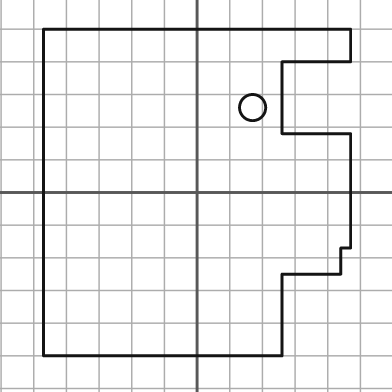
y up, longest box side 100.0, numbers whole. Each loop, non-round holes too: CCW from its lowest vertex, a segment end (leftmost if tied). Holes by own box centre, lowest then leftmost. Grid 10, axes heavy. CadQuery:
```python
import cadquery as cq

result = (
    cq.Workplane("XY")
    .moveTo(-47.0, -50.0)
    .lineTo(26.0, -50.0)
    .lineTo(26.0, -25.0)
    .lineTo(44.0, -25.0)
    .lineTo(44.0, -17.0)
    .lineTo(47.0, -17.0)
    .lineTo(47.0, 18.0)
    .lineTo(26.0, 18.0)
    .lineTo(26.0, 40.0)
    .lineTo(47.0, 40.0)
    .lineTo(47.0, 50.0)
    .lineTo(-47.0, 50.0)
    .close()
    .moveTo(17.0, 26.0)
    .circle(4.0)
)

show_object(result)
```